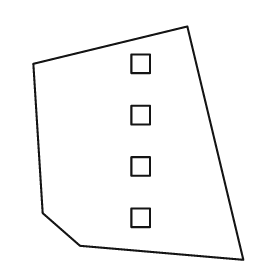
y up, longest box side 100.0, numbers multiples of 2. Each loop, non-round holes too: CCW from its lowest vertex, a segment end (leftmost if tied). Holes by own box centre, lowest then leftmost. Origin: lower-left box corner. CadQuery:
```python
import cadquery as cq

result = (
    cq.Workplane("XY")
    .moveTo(90.0, 0.0)
    .lineTo(66.0, 100.0)
    .lineTo(0.0, 84.0)
    .lineTo(4.0, 20.0)
    .lineTo(20.0, 6.0)
    .close()
    .moveTo(42.0, 14.0)
    .lineTo(50.0, 14.0)
    .lineTo(50.0, 22.0)
    .lineTo(42.0, 22.0)
    .close()
    .moveTo(42.0, 36.0)
    .lineTo(50.0, 36.0)
    .lineTo(50.0, 44.0)
    .lineTo(42.0, 44.0)
    .close()
    .moveTo(42.0, 58.0)
    .lineTo(50.0, 58.0)
    .lineTo(50.0, 66.0)
    .lineTo(42.0, 66.0)
    .close()
    .moveTo(42.0, 80.0)
    .lineTo(50.0, 80.0)
    .lineTo(50.0, 88.0)
    .lineTo(42.0, 88.0)
    .close()
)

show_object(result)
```